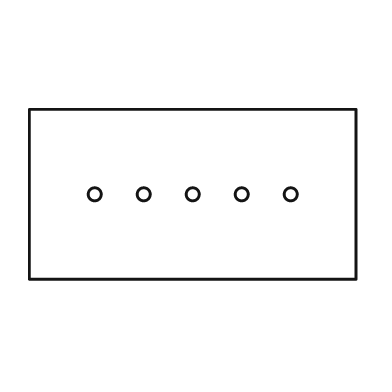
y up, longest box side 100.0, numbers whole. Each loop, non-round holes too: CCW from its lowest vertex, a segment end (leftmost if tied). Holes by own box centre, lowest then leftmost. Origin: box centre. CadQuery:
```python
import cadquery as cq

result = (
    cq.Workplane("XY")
    .moveTo(-50.0, -26.0)
    .lineTo(50.0, -26.0)
    .lineTo(50.0, 26.0)
    .lineTo(-50.0, 26.0)
    .close()
    .moveTo(-30.0, 0.0)
    .circle(2.0)
    .moveTo(-15.0, 0.0)
    .circle(2.0)
    .moveTo(0.0, 0.0)
    .circle(2.0)
    .moveTo(15.0, 0.0)
    .circle(2.0)
    .moveTo(30.0, 0.0)
    .circle(2.0)
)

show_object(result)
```